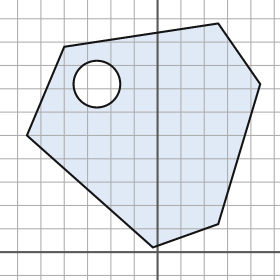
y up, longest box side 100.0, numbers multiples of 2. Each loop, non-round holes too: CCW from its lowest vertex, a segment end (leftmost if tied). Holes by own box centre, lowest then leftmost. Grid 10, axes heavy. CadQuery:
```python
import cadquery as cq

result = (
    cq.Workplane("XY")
    .moveTo(-2.0, 2.0)
    .lineTo(26.0, 12.0)
    .lineTo(44.0, 72.0)
    .lineTo(26.0, 98.0)
    .lineTo(-40.0, 88.0)
    .lineTo(-56.0, 50.0)
    .close()
    .moveTo(-26.0, 72.0)
    .circle(10.0)
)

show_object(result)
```